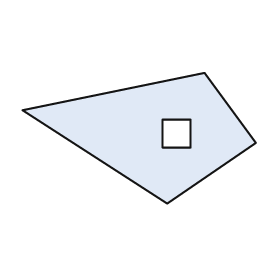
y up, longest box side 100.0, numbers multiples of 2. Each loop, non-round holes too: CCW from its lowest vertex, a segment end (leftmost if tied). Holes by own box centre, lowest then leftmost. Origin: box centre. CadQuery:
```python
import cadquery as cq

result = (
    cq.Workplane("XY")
    .moveTo(12.0, -28.0)
    .lineTo(50.0, -2.0)
    .lineTo(28.0, 28.0)
    .lineTo(-50.0, 12.0)
    .close()
    .moveTo(10.0, -4.0)
    .lineTo(22.0, -4.0)
    .lineTo(22.0, 8.0)
    .lineTo(10.0, 8.0)
    .close()
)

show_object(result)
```